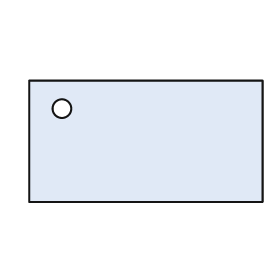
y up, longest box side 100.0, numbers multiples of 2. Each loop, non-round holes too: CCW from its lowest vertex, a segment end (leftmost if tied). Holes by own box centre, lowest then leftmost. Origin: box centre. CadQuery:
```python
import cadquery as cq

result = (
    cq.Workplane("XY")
    .moveTo(-50.0, -26.0)
    .lineTo(50.0, -26.0)
    .lineTo(50.0, 26.0)
    .lineTo(-50.0, 26.0)
    .close()
    .moveTo(-36.0, 14.0)
    .circle(4.0)
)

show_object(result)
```